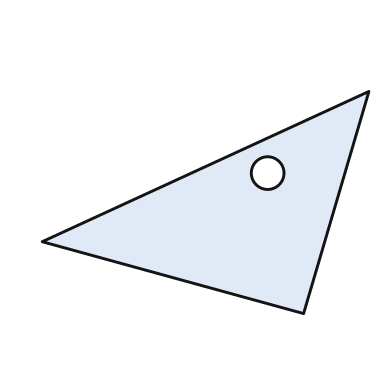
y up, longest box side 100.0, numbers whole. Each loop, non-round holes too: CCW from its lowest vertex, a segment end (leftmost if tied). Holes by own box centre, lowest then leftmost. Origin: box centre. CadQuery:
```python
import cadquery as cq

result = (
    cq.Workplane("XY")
    .moveTo(30.0, -34.0)
    .lineTo(50.0, 34.0)
    .lineTo(-50.0, -12.0)
    .close()
    .moveTo(19.0, 9.0)
    .circle(5.0)
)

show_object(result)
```